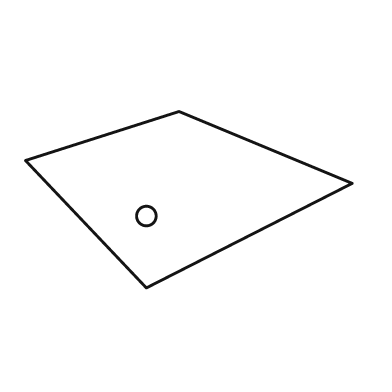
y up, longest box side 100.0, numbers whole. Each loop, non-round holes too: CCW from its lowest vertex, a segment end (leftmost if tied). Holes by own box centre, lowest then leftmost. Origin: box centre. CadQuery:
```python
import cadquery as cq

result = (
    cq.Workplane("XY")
    .moveTo(-13.0, -27.0)
    .lineTo(50.0, 5.0)
    .lineTo(-3.0, 27.0)
    .lineTo(-50.0, 12.0)
    .close()
    .moveTo(-13.0, -5.0)
    .circle(3.0)
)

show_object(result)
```